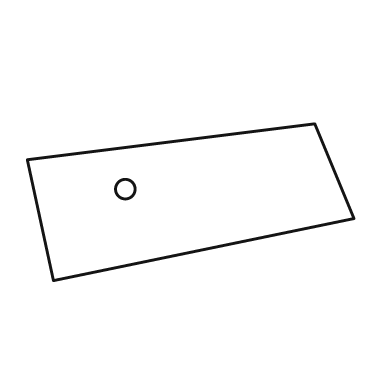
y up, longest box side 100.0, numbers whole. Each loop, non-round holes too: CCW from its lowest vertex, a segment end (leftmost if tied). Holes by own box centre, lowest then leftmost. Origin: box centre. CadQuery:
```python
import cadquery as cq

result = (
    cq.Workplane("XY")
    .moveTo(-42.0, -24.0)
    .lineTo(50.0, -5.0)
    .lineTo(38.0, 24.0)
    .lineTo(-50.0, 13.0)
    .close()
    .moveTo(-20.0, 4.0)
    .circle(3.0)
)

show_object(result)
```